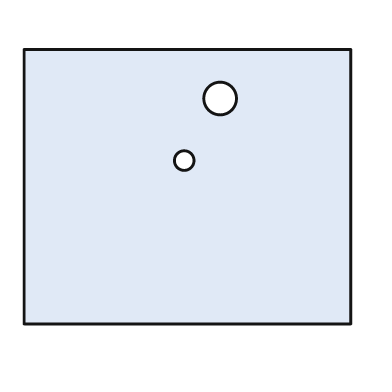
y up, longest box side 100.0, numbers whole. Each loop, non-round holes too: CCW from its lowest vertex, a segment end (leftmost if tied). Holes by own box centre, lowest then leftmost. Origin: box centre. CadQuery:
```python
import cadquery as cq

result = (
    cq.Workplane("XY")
    .moveTo(-50.0, -42.0)
    .lineTo(50.0, -42.0)
    .lineTo(50.0, 42.0)
    .lineTo(-50.0, 42.0)
    .close()
    .moveTo(-1.0, 8.0)
    .circle(3.0)
    .moveTo(10.0, 27.0)
    .circle(5.0)
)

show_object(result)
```